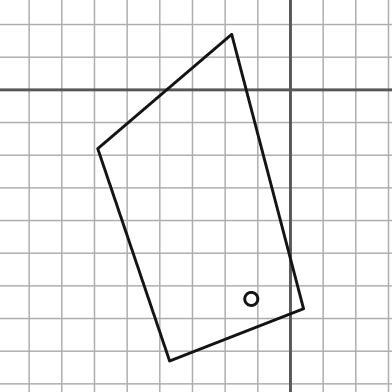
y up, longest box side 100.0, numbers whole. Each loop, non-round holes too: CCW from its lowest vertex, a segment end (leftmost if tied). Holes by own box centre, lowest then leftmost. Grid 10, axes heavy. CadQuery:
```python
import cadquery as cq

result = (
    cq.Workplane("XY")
    .moveTo(-37.0, -83.0)
    .lineTo(4.0, -67.0)
    .lineTo(-18.0, 17.0)
    .lineTo(-59.0, -18.0)
    .close()
    .moveTo(-12.0, -64.0)
    .circle(2.0)
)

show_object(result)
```